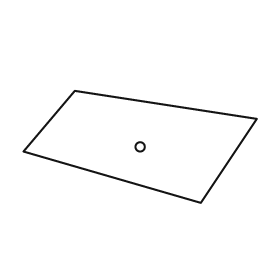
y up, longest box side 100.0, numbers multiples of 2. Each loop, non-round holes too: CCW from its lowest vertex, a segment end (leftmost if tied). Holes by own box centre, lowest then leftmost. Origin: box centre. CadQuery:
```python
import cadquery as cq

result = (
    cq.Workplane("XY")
    .moveTo(26.0, -24.0)
    .lineTo(50.0, 12.0)
    .lineTo(-28.0, 24.0)
    .lineTo(-50.0, -2.0)
    .close()
    .moveTo(0.0, 0.0)
    .circle(2.0)
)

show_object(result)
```